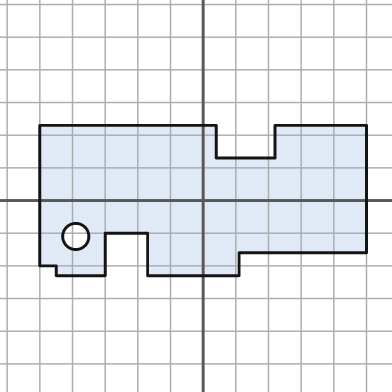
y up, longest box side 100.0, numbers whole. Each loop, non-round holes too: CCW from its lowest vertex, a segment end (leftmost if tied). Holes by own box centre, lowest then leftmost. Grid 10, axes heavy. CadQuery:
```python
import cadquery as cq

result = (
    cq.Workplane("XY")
    .moveTo(-45.0, -23.0)
    .lineTo(-30.0, -23.0)
    .lineTo(-30.0, -10.0)
    .lineTo(-17.0, -10.0)
    .lineTo(-17.0, -23.0)
    .lineTo(11.0, -23.0)
    .lineTo(11.0, -16.0)
    .lineTo(50.0, -16.0)
    .lineTo(50.0, 23.0)
    .lineTo(22.0, 23.0)
    .lineTo(22.0, 13.0)
    .lineTo(4.0, 13.0)
    .lineTo(4.0, 23.0)
    .lineTo(-50.0, 23.0)
    .lineTo(-50.0, -20.0)
    .lineTo(-45.0, -20.0)
    .close()
    .moveTo(-39.0, -11.0)
    .circle(4.0)
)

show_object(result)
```